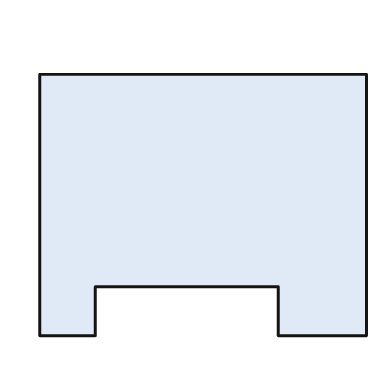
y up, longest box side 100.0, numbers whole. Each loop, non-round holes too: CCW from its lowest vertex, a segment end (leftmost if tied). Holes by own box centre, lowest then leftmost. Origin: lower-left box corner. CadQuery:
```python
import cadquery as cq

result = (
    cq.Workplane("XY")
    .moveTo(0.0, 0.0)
    .lineTo(17.0, 0.0)
    .lineTo(17.0, 15.0)
    .lineTo(73.0, 15.0)
    .lineTo(73.0, 0.0)
    .lineTo(100.0, 0.0)
    .lineTo(100.0, 80.0)
    .lineTo(0.0, 80.0)
    .close()
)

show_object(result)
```